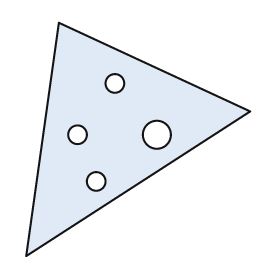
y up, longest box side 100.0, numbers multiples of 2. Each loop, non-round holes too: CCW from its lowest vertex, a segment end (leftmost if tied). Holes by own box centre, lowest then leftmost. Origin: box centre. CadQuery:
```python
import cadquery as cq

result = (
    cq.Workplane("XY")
    .moveTo(-48.0, -50.0)
    .lineTo(48.0, 12.0)
    .lineTo(-34.0, 50.0)
    .close()
    .moveTo(-18.0, -18.0)
    .circle(4.0)
    .moveTo(-26.0, 2.0)
    .circle(4.0)
    .moveTo(8.0, 2.0)
    .circle(6.0)
    .moveTo(-10.0, 24.0)
    .circle(4.0)
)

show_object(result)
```